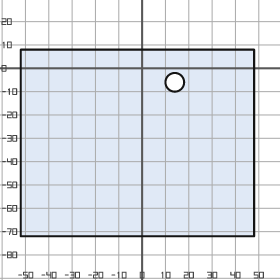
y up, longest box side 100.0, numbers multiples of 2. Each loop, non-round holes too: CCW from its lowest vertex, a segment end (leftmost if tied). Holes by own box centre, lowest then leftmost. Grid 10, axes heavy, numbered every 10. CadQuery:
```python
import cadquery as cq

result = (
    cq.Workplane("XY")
    .moveTo(-52.0, -72.0)
    .lineTo(48.0, -72.0)
    .lineTo(48.0, 8.0)
    .lineTo(-52.0, 8.0)
    .close()
    .moveTo(14.0, -6.0)
    .circle(4.0)
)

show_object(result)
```